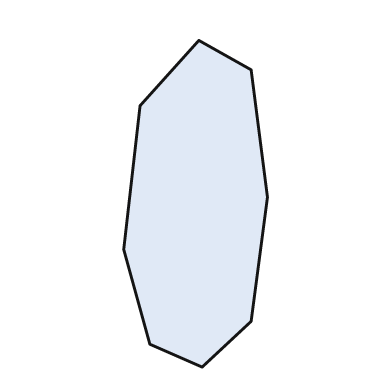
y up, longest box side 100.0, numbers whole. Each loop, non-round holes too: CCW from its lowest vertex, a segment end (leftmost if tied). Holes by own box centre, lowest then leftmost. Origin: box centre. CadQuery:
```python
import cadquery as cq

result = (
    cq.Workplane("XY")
    .moveTo(2.0, -50.0)
    .lineTo(17.0, -36.0)
    .lineTo(22.0, 2.0)
    .lineTo(17.0, 41.0)
    .lineTo(1.0, 50.0)
    .lineTo(-17.0, 30.0)
    .lineTo(-22.0, -14.0)
    .lineTo(-14.0, -43.0)
    .close()
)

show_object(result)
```